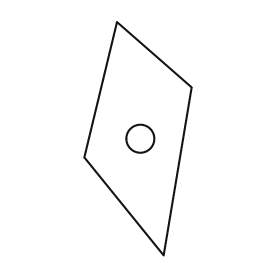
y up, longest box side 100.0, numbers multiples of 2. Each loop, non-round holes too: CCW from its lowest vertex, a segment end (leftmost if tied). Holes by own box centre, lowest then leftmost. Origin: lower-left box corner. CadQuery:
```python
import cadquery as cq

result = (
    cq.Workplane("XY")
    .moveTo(34.0, 0.0)
    .lineTo(46.0, 72.0)
    .lineTo(14.0, 100.0)
    .lineTo(0.0, 42.0)
    .close()
    .moveTo(24.0, 50.0)
    .circle(6.0)
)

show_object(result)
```